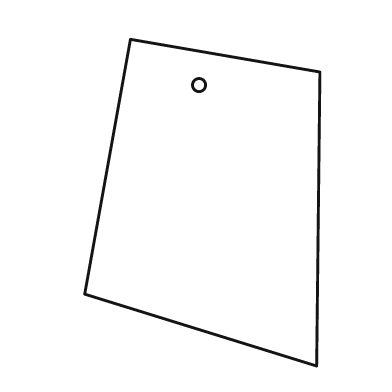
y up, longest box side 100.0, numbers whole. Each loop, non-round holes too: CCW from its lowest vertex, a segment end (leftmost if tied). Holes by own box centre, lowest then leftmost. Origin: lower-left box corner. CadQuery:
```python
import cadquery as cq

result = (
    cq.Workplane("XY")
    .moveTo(71.0, 0.0)
    .lineTo(72.0, 90.0)
    .lineTo(14.0, 100.0)
    .lineTo(0.0, 22.0)
    .close()
    .moveTo(35.0, 86.0)
    .circle(2.0)
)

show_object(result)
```